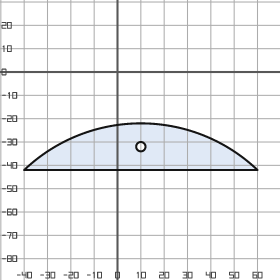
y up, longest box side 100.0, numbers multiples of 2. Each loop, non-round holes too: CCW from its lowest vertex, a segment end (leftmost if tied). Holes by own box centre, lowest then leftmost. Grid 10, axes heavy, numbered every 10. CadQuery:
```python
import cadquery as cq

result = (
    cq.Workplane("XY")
    .moveTo(-40.0, -42.0)
    .lineTo(60.0, -42.0)
    .threePointArc((10.0, -22.0), (-40.0, -42.0))
    .close()
    .moveTo(10.0, -32.0)
    .circle(2.0)
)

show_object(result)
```